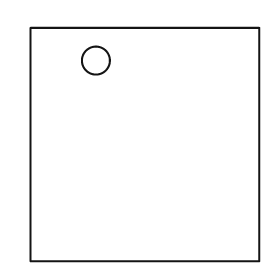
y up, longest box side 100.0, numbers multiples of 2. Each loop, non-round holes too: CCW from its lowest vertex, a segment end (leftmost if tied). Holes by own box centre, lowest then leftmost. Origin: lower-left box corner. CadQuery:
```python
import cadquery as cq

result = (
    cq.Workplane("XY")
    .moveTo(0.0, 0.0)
    .lineTo(98.0, 0.0)
    .lineTo(98.0, 100.0)
    .lineTo(0.0, 100.0)
    .close()
    .moveTo(28.0, 86.0)
    .circle(6.0)
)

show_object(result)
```